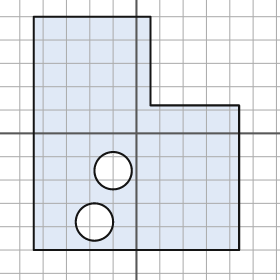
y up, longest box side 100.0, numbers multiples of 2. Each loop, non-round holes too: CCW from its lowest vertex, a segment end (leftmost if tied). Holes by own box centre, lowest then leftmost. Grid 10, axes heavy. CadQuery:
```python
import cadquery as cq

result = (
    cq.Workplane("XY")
    .moveTo(-44.0, -50.0)
    .lineTo(44.0, -50.0)
    .lineTo(44.0, 12.0)
    .lineTo(6.0, 12.0)
    .lineTo(6.0, 50.0)
    .lineTo(-44.0, 50.0)
    .close()
    .moveTo(-18.0, -38.0)
    .circle(8.0)
    .moveTo(-10.0, -16.0)
    .circle(8.0)
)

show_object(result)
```